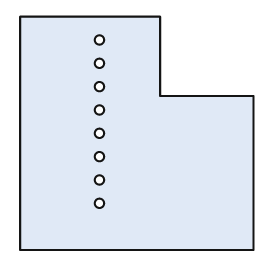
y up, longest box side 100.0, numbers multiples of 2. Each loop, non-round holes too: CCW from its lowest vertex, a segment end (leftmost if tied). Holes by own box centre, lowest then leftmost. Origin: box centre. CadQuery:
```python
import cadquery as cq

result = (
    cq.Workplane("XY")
    .moveTo(-50.0, -50.0)
    .lineTo(50.0, -50.0)
    .lineTo(50.0, 16.0)
    .lineTo(10.0, 16.0)
    .lineTo(10.0, 50.0)
    .lineTo(-50.0, 50.0)
    .close()
    .moveTo(-16.0, -30.0)
    .circle(2.0)
    .moveTo(-16.0, -20.0)
    .circle(2.0)
    .moveTo(-16.0, -10.0)
    .circle(2.0)
    .moveTo(-16.0, 0.0)
    .circle(2.0)
    .moveTo(-16.0, 10.0)
    .circle(2.0)
    .moveTo(-16.0, 20.0)
    .circle(2.0)
    .moveTo(-16.0, 30.0)
    .circle(2.0)
    .moveTo(-16.0, 40.0)
    .circle(2.0)
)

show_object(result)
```